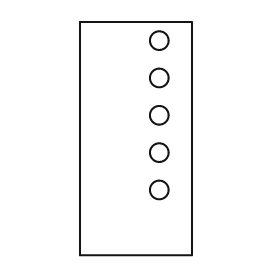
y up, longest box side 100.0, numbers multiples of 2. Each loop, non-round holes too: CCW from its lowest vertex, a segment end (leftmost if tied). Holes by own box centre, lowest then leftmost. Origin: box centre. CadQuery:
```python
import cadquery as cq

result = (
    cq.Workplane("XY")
    .moveTo(-24.0, -50.0)
    .lineTo(24.0, -50.0)
    .lineTo(24.0, 50.0)
    .lineTo(-24.0, 50.0)
    .close()
    .moveTo(10.0, -22.0)
    .circle(4.0)
    .moveTo(10.0, -6.0)
    .circle(4.0)
    .moveTo(10.0, 10.0)
    .circle(4.0)
    .moveTo(10.0, 26.0)
    .circle(4.0)
    .moveTo(10.0, 42.0)
    .circle(4.0)
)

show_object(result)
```